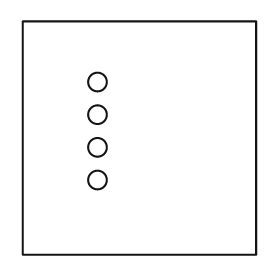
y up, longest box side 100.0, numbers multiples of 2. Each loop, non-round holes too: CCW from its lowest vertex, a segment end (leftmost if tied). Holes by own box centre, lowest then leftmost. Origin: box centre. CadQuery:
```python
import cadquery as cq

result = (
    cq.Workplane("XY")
    .moveTo(-50.0, -50.0)
    .lineTo(50.0, -50.0)
    .lineTo(50.0, 50.0)
    .lineTo(-50.0, 50.0)
    .close()
    .moveTo(-18.0, -18.0)
    .circle(4.0)
    .moveTo(-18.0, -4.0)
    .circle(4.0)
    .moveTo(-18.0, 10.0)
    .circle(4.0)
    .moveTo(-18.0, 24.0)
    .circle(4.0)
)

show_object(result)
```